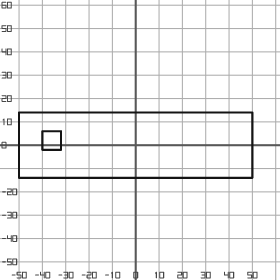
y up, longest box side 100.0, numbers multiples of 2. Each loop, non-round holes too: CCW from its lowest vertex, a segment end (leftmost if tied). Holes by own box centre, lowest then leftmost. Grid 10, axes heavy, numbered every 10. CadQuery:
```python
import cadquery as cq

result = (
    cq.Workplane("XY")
    .moveTo(-50.0, -14.0)
    .lineTo(50.0, -14.0)
    .lineTo(50.0, 14.0)
    .lineTo(-50.0, 14.0)
    .close()
    .moveTo(-40.0, -2.0)
    .lineTo(-32.0, -2.0)
    .lineTo(-32.0, 6.0)
    .lineTo(-40.0, 6.0)
    .close()
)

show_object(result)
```